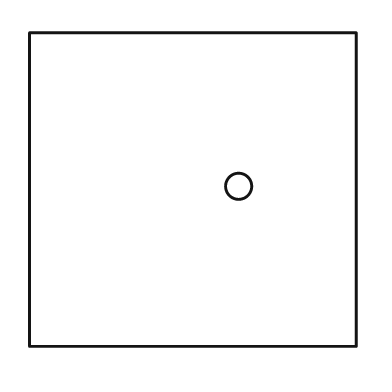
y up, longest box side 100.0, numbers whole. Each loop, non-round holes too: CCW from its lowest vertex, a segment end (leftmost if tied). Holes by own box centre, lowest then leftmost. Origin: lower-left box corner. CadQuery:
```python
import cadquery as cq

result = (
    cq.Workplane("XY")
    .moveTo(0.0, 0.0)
    .lineTo(100.0, 0.0)
    .lineTo(100.0, 96.0)
    .lineTo(0.0, 96.0)
    .close()
    .moveTo(64.0, 49.0)
    .circle(4.0)
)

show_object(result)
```